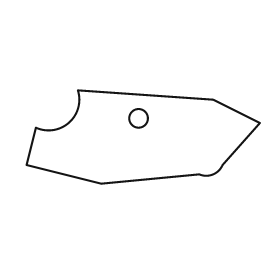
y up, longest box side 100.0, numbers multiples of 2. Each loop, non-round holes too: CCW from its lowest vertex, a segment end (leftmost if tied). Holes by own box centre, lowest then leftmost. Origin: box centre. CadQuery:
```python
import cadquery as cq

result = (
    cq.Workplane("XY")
    .moveTo(-18.0, -20.0)
    .lineTo(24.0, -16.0)
    .threePointArc((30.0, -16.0), (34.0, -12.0))
    .lineTo(50.0, 6.0)
    .lineTo(30.0, 16.0)
    .lineTo(-28.0, 20.0)
    .threePointArc((-32.0, 6.0), (-46.0, 4.0))
    .lineTo(-50.0, -12.0)
    .close()
    .moveTo(-2.0, 8.0)
    .circle(4.0)
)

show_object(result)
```